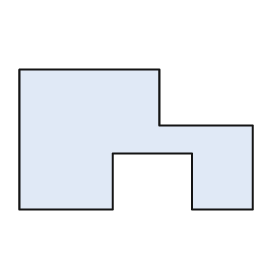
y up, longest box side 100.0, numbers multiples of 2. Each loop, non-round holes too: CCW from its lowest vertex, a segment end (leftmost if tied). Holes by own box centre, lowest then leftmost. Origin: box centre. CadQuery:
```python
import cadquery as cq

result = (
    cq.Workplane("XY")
    .moveTo(-50.0, -30.0)
    .lineTo(-10.0, -30.0)
    .lineTo(-10.0, -6.0)
    .lineTo(24.0, -6.0)
    .lineTo(24.0, -30.0)
    .lineTo(50.0, -30.0)
    .lineTo(50.0, 6.0)
    .lineTo(10.0, 6.0)
    .lineTo(10.0, 30.0)
    .lineTo(-50.0, 30.0)
    .close()
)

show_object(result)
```